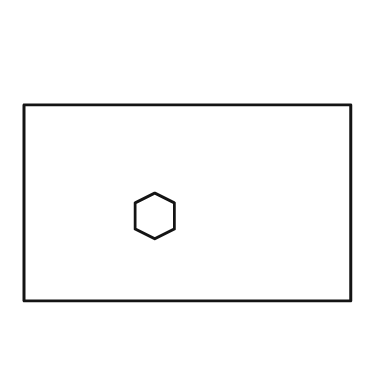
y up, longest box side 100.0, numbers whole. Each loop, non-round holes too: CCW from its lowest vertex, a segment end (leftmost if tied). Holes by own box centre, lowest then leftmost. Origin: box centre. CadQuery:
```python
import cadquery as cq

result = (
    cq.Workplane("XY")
    .moveTo(-50.0, -30.0)
    .lineTo(50.0, -30.0)
    .lineTo(50.0, 30.0)
    .lineTo(-50.0, 30.0)
    .close()
    .moveTo(-10.0, -11.0)
    .lineTo(-4.0, -8.0)
    .lineTo(-4.0, 0.0)
    .lineTo(-10.0, 3.0)
    .lineTo(-16.0, 0.0)
    .lineTo(-16.0, -8.0)
    .close()
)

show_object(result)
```